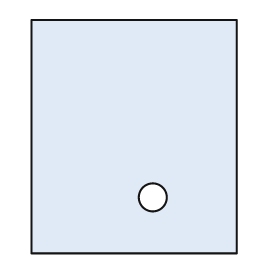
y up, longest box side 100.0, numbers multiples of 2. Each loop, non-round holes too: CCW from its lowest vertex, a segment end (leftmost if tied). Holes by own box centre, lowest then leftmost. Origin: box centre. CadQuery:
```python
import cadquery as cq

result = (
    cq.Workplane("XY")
    .moveTo(-44.0, -50.0)
    .lineTo(44.0, -50.0)
    .lineTo(44.0, 50.0)
    .lineTo(-44.0, 50.0)
    .close()
    .moveTo(8.0, -26.0)
    .circle(6.0)
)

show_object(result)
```